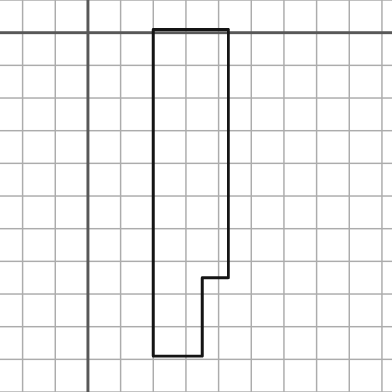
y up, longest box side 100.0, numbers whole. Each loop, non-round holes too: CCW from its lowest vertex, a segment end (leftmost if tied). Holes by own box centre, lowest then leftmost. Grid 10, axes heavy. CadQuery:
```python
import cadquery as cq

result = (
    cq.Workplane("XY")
    .moveTo(20.0, -99.0)
    .lineTo(35.0, -99.0)
    .lineTo(35.0, -75.0)
    .lineTo(43.0, -75.0)
    .lineTo(43.0, 1.0)
    .lineTo(20.0, 1.0)
    .close()
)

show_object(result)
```